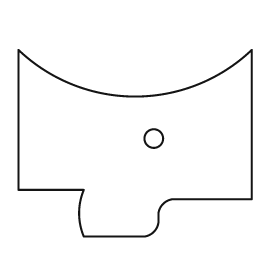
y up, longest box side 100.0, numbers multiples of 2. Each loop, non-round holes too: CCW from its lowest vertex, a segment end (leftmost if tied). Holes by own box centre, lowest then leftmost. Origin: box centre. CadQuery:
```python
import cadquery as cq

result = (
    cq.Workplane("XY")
    .moveTo(-22.0, -40.0)
    .lineTo(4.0, -40.0)
    .threePointArc((8.0, -38.0), (10.0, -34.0))
    .lineTo(10.0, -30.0)
    .threePointArc((12.0, -26.0), (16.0, -24.0))
    .lineTo(50.0, -24.0)
    .lineTo(50.0, 40.0)
    .threePointArc((0.0, 20.0), (-50.0, 40.0))
    .lineTo(-50.0, -20.0)
    .lineTo(-22.0, -20.0)
    .threePointArc((-24.0, -30.0), (-22.0, -40.0))
    .close()
    .moveTo(8.0, 2.0)
    .circle(4.0)
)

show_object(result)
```